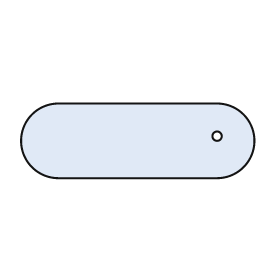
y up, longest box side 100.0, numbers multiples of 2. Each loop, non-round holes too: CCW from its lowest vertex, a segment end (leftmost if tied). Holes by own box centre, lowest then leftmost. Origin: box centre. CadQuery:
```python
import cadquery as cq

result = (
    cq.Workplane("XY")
    .moveTo(-34.0, -16.0)
    .lineTo(34.0, -16.0)
    .threePointArc((50.0, 0.0), (34.0, 16.0))
    .lineTo(-34.0, 16.0)
    .threePointArc((-50.0, 0.0), (-34.0, -16.0))
    .close()
    .moveTo(34.0, 2.0)
    .circle(2.0)
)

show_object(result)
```